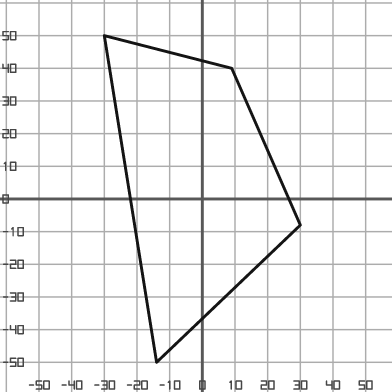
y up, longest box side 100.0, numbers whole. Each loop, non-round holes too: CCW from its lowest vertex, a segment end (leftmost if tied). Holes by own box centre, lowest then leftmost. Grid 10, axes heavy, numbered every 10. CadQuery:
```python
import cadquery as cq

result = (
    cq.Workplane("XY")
    .moveTo(-14.0, -50.0)
    .lineTo(30.0, -8.0)
    .lineTo(9.0, 40.0)
    .lineTo(-30.0, 50.0)
    .close()
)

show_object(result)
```